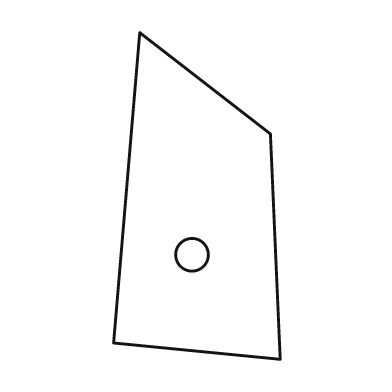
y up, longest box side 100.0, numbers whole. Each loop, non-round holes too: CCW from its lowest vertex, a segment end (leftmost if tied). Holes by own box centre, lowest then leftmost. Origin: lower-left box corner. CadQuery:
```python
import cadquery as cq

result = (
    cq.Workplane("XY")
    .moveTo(51.0, 0.0)
    .lineTo(48.0, 69.0)
    .lineTo(8.0, 100.0)
    .lineTo(0.0, 5.0)
    .close()
    .moveTo(24.0, 32.0)
    .circle(5.0)
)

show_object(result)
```